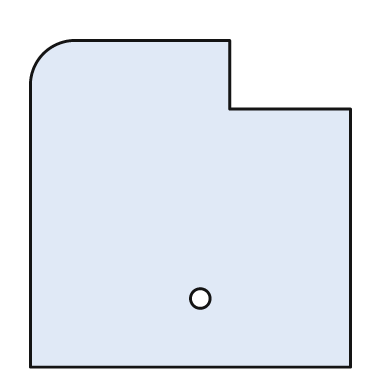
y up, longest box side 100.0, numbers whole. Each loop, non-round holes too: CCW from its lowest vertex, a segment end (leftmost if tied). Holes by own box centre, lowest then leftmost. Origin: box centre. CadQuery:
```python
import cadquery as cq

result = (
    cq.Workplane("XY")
    .moveTo(-49.0, -50.0)
    .lineTo(49.0, -50.0)
    .lineTo(49.0, 29.0)
    .lineTo(12.0, 29.0)
    .lineTo(12.0, 50.0)
    .lineTo(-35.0, 50.0)
    .threePointArc((-45.0, 46.0), (-49.0, 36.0))
    .close()
    .moveTo(3.0, -29.0)
    .circle(3.0)
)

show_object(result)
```